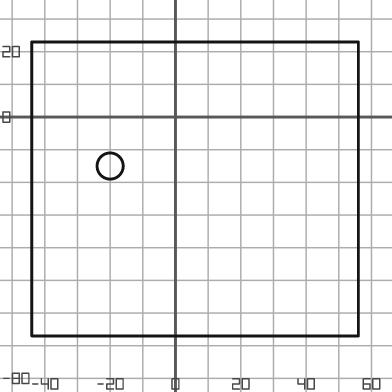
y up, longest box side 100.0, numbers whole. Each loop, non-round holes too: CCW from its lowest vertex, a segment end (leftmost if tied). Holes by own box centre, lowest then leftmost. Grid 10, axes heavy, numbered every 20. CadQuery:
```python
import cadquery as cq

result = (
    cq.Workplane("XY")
    .moveTo(-44.0, -67.0)
    .lineTo(56.0, -67.0)
    .lineTo(56.0, 23.0)
    .lineTo(-44.0, 23.0)
    .close()
    .moveTo(-20.0, -15.0)
    .circle(4.0)
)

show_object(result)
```